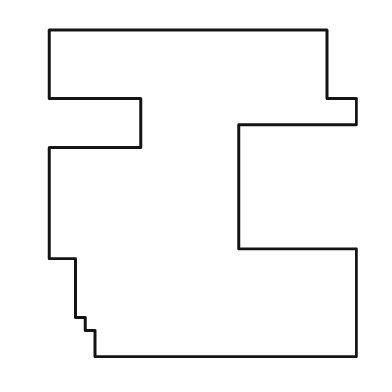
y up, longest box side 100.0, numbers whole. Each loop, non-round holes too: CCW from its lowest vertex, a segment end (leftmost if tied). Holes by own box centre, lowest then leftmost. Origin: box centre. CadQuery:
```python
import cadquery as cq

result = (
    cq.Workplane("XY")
    .moveTo(-33.0, -50.0)
    .lineTo(47.0, -50.0)
    .lineTo(47.0, -17.0)
    .lineTo(11.0, -17.0)
    .lineTo(11.0, 21.0)
    .lineTo(47.0, 21.0)
    .lineTo(47.0, 29.0)
    .lineTo(38.0, 29.0)
    .lineTo(38.0, 50.0)
    .lineTo(-47.0, 50.0)
    .lineTo(-47.0, 29.0)
    .lineTo(-19.0, 29.0)
    .lineTo(-19.0, 14.0)
    .lineTo(-47.0, 14.0)
    .lineTo(-47.0, -20.0)
    .lineTo(-39.0, -20.0)
    .lineTo(-39.0, -38.0)
    .lineTo(-36.0, -38.0)
    .lineTo(-36.0, -42.0)
    .lineTo(-33.0, -42.0)
    .close()
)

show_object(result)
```